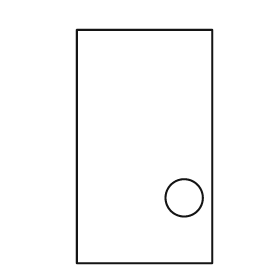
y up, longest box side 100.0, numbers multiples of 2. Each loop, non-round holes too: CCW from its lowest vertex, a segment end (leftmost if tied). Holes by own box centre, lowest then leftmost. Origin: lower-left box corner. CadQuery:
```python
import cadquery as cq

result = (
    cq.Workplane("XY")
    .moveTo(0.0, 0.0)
    .lineTo(58.0, 0.0)
    .lineTo(58.0, 100.0)
    .lineTo(0.0, 100.0)
    .close()
    .moveTo(46.0, 28.0)
    .circle(8.0)
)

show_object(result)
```